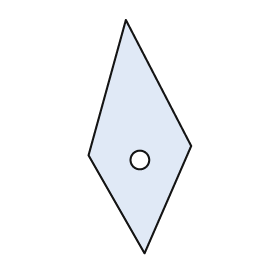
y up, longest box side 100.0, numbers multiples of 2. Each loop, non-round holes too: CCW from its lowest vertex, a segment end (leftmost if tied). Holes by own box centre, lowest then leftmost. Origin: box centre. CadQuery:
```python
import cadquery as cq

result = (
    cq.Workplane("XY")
    .moveTo(2.0, -50.0)
    .lineTo(22.0, -4.0)
    .lineTo(-6.0, 50.0)
    .lineTo(-22.0, -8.0)
    .close()
    .moveTo(0.0, -10.0)
    .circle(4.0)
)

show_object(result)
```